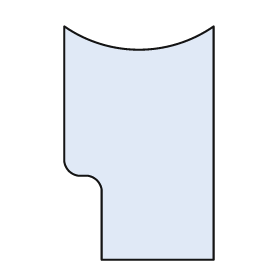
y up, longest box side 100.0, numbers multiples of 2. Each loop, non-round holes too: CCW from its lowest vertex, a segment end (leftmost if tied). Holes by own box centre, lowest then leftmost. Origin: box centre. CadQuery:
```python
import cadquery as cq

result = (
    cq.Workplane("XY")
    .moveTo(-16.0, -50.0)
    .lineTo(32.0, -50.0)
    .lineTo(32.0, 50.0)
    .threePointArc((0.0, 40.0), (-32.0, 50.0))
    .lineTo(-32.0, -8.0)
    .threePointArc((-30.0, -12.0), (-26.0, -14.0))
    .lineTo(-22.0, -14.0)
    .threePointArc((-18.0, -16.0), (-16.0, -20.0))
    .close()
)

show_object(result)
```